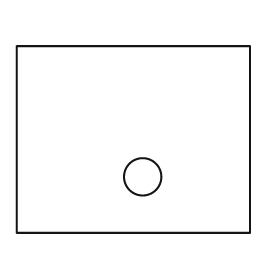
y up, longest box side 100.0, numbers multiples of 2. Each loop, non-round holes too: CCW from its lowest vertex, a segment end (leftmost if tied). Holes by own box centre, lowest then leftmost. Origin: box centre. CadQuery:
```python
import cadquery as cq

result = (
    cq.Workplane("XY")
    .moveTo(-50.0, -40.0)
    .lineTo(50.0, -40.0)
    .lineTo(50.0, 40.0)
    .lineTo(-50.0, 40.0)
    .close()
    .moveTo(4.0, -16.0)
    .circle(8.0)
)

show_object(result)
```